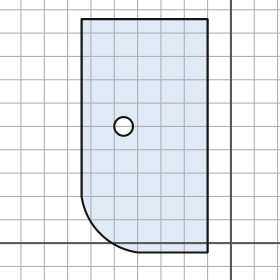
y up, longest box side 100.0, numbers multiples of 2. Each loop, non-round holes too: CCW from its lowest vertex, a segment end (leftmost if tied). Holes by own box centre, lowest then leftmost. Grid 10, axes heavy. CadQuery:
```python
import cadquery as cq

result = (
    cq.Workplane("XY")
    .moveTo(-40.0, -4.0)
    .lineTo(-10.0, -4.0)
    .lineTo(-10.0, 96.0)
    .lineTo(-64.0, 96.0)
    .lineTo(-64.0, 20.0)
    .threePointArc((-56.0, 4.0), (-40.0, -4.0))
    .close()
    .moveTo(-46.0, 50.0)
    .circle(4.0)
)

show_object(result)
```